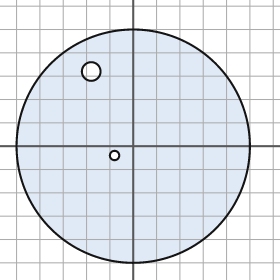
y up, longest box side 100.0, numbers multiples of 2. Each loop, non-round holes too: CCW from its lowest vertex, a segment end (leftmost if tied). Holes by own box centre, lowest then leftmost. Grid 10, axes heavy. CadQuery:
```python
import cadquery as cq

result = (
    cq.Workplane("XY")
    .moveTo(0.0, 0.0)
    .circle(50.0)
    .moveTo(-8.0, -4.0)
    .circle(2.0)
    .moveTo(-18.0, 32.0)
    .circle(4.0)
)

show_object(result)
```